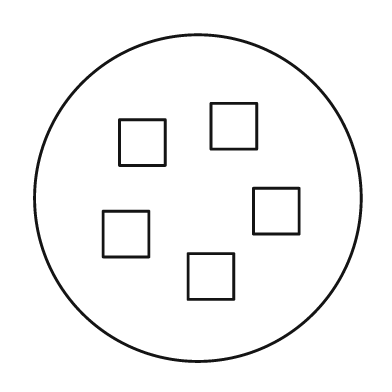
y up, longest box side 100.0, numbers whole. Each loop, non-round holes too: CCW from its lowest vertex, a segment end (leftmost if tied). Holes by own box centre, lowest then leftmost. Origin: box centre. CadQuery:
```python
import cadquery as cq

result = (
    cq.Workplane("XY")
    .moveTo(0.0, 0.0)
    .circle(50.0)
    .moveTo(-3.0, -31.0)
    .lineTo(11.0, -31.0)
    .lineTo(11.0, -17.0)
    .lineTo(-3.0, -17.0)
    .close()
    .moveTo(-29.0, -18.0)
    .lineTo(-15.0, -18.0)
    .lineTo(-15.0, -4.0)
    .lineTo(-29.0, -4.0)
    .close()
    .moveTo(17.0, -11.0)
    .lineTo(31.0, -11.0)
    .lineTo(31.0, 3.0)
    .lineTo(17.0, 3.0)
    .close()
    .moveTo(-24.0, 10.0)
    .lineTo(-10.0, 10.0)
    .lineTo(-10.0, 24.0)
    .lineTo(-24.0, 24.0)
    .close()
    .moveTo(4.0, 15.0)
    .lineTo(18.0, 15.0)
    .lineTo(18.0, 29.0)
    .lineTo(4.0, 29.0)
    .close()
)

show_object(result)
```